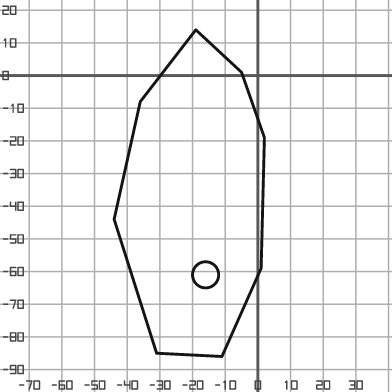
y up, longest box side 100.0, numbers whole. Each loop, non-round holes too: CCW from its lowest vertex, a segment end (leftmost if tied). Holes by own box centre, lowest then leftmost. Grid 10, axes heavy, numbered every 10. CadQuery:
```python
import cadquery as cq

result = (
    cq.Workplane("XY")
    .moveTo(-11.0, -86.0)
    .lineTo(1.0, -59.0)
    .lineTo(2.0, -19.0)
    .lineTo(-5.0, 1.0)
    .lineTo(-19.0, 14.0)
    .lineTo(-36.0, -8.0)
    .lineTo(-44.0, -44.0)
    .lineTo(-31.0, -85.0)
    .close()
    .moveTo(-16.0, -61.0)
    .circle(4.0)
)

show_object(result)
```